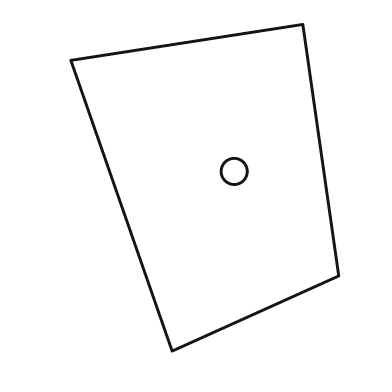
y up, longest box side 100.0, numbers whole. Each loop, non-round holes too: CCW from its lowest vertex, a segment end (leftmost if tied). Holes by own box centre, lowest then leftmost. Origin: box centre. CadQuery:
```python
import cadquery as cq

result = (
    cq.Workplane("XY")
    .moveTo(-10.0, -50.0)
    .lineTo(41.0, -27.0)
    .lineTo(30.0, 50.0)
    .lineTo(-41.0, 39.0)
    .close()
    .moveTo(9.0, 5.0)
    .circle(4.0)
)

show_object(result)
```